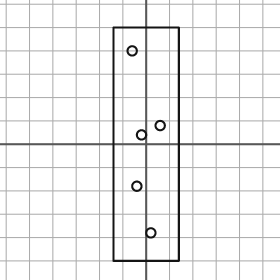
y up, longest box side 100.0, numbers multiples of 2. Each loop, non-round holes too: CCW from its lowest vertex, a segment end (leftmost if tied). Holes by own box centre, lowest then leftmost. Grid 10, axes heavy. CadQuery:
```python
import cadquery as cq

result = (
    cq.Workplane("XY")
    .moveTo(-14.0, -50.0)
    .lineTo(14.0, -50.0)
    .lineTo(14.0, 50.0)
    .lineTo(-14.0, 50.0)
    .close()
    .moveTo(2.0, -38.0)
    .circle(2.0)
    .moveTo(-4.0, -18.0)
    .circle(2.0)
    .moveTo(-2.0, 4.0)
    .circle(2.0)
    .moveTo(6.0, 8.0)
    .circle(2.0)
    .moveTo(-6.0, 40.0)
    .circle(2.0)
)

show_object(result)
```